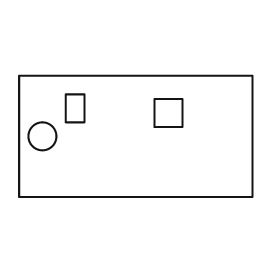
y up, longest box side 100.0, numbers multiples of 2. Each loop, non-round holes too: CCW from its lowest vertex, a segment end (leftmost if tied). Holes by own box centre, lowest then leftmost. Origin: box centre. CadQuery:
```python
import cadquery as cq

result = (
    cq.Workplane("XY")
    .moveTo(-50.0, -26.0)
    .lineTo(50.0, -26.0)
    .lineTo(50.0, 26.0)
    .lineTo(-50.0, 26.0)
    .close()
    .moveTo(-40.0, 0.0)
    .circle(6.0)
    .moveTo(8.0, 4.0)
    .lineTo(20.0, 4.0)
    .lineTo(20.0, 16.0)
    .lineTo(8.0, 16.0)
    .close()
    .moveTo(-30.0, 6.0)
    .lineTo(-22.0, 6.0)
    .lineTo(-22.0, 18.0)
    .lineTo(-30.0, 18.0)
    .close()
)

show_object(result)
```